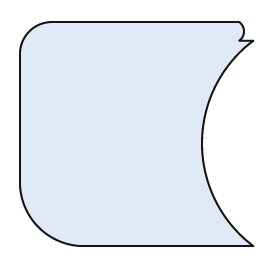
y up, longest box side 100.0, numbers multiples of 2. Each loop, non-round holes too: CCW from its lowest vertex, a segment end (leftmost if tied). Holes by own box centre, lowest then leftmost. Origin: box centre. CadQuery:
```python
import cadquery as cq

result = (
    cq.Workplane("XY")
    .moveTo(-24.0, -48.0)
    .lineTo(50.0, -48.0)
    .threePointArc((28.0, -4.0), (50.0, 40.0))
    .lineTo(44.0, 40.0)
    .threePointArc((46.0, 44.0), (44.0, 48.0))
    .lineTo(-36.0, 48.0)
    .threePointArc((-46.0, 44.0), (-50.0, 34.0))
    .lineTo(-50.0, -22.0)
    .threePointArc((-42.0, -40.0), (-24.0, -48.0))
    .close()
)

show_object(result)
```